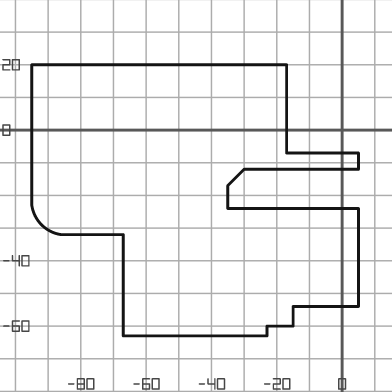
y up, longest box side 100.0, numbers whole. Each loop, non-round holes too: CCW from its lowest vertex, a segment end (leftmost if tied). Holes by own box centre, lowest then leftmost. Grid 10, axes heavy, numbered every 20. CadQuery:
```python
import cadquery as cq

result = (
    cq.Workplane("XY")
    .moveTo(-67.0, -63.0)
    .lineTo(-23.0, -63.0)
    .lineTo(-23.0, -60.0)
    .lineTo(-15.0, -60.0)
    .lineTo(-15.0, -54.0)
    .lineTo(5.0, -54.0)
    .lineTo(5.0, -24.0)
    .lineTo(-35.0, -24.0)
    .lineTo(-35.0, -17.0)
    .lineTo(-30.0, -12.0)
    .lineTo(5.0, -12.0)
    .lineTo(5.0, -7.0)
    .lineTo(-17.0, -7.0)
    .lineTo(-17.0, 20.0)
    .lineTo(-95.0, 20.0)
    .lineTo(-95.0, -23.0)
    .threePointArc((-92.0, -29.0), (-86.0, -32.0))
    .lineTo(-67.0, -32.0)
    .close()
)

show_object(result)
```